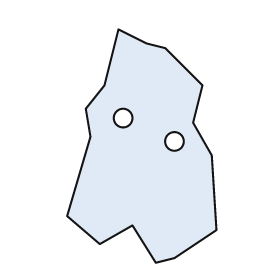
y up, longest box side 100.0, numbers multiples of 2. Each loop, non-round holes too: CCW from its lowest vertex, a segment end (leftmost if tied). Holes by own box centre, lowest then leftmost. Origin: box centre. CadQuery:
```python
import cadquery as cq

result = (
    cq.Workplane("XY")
    .moveTo(6.0, -50.0)
    .lineTo(14.0, -48.0)
    .lineTo(32.0, -36.0)
    .lineTo(30.0, -4.0)
    .lineTo(22.0, 10.0)
    .lineTo(26.0, 26.0)
    .lineTo(10.0, 42.0)
    .lineTo(2.0, 44.0)
    .lineTo(-10.0, 50.0)
    .lineTo(-16.0, 26.0)
    .lineTo(-24.0, 16.0)
    .lineTo(-22.0, 4.0)
    .lineTo(-32.0, -30.0)
    .lineTo(-18.0, -42.0)
    .lineTo(-4.0, -34.0)
    .close()
    .moveTo(14.0, 2.0)
    .circle(4.0)
    .moveTo(-8.0, 12.0)
    .circle(4.0)
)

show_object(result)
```